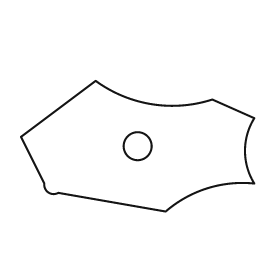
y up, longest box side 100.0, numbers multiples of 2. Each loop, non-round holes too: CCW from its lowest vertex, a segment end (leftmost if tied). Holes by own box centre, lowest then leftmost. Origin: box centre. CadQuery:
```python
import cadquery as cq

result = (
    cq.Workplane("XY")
    .moveTo(12.0, -28.0)
    .threePointArc((30.0, -18.0), (50.0, -16.0))
    .threePointArc((46.0, -2.0), (50.0, 12.0))
    .lineTo(32.0, 20.0)
    .threePointArc((6.0, 18.0), (-18.0, 28.0))
    .lineTo(-50.0, 4.0)
    .lineTo(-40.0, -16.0)
    .threePointArc((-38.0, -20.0), (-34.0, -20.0))
    .close()
    .moveTo(0.0, 0.0)
    .circle(6.0)
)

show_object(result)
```